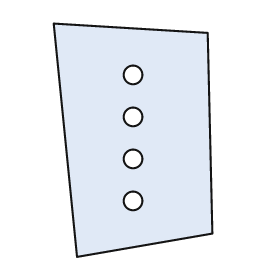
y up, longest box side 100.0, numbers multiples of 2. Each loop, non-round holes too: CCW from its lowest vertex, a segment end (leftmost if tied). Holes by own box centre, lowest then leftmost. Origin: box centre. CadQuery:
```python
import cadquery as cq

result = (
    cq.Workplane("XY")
    .moveTo(-24.0, -50.0)
    .lineTo(34.0, -40.0)
    .lineTo(32.0, 46.0)
    .lineTo(-34.0, 50.0)
    .close()
    .moveTo(0.0, -26.0)
    .circle(4.0)
    .moveTo(0.0, -8.0)
    .circle(4.0)
    .moveTo(0.0, 10.0)
    .circle(4.0)
    .moveTo(0.0, 28.0)
    .circle(4.0)
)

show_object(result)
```